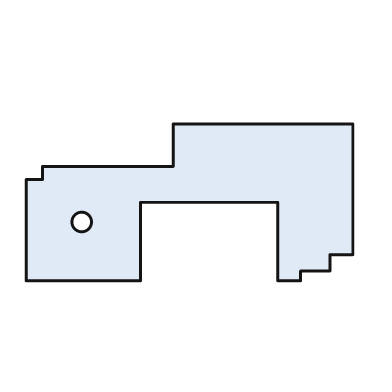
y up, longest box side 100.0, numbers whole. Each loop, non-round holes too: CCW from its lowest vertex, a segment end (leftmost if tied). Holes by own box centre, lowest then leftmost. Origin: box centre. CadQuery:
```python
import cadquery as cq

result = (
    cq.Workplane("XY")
    .moveTo(-50.0, -24.0)
    .lineTo(-15.0, -24.0)
    .lineTo(-15.0, 0.0)
    .lineTo(27.0, 0.0)
    .lineTo(27.0, -24.0)
    .lineTo(34.0, -24.0)
    .lineTo(34.0, -21.0)
    .lineTo(43.0, -21.0)
    .lineTo(43.0, -16.0)
    .lineTo(50.0, -16.0)
    .lineTo(50.0, 24.0)
    .lineTo(-5.0, 24.0)
    .lineTo(-5.0, 11.0)
    .lineTo(-45.0, 11.0)
    .lineTo(-45.0, 7.0)
    .lineTo(-50.0, 7.0)
    .close()
    .moveTo(-33.0, -6.0)
    .circle(3.0)
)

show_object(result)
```